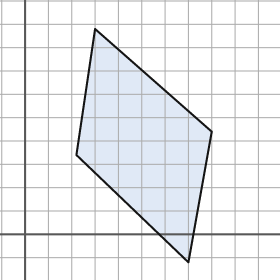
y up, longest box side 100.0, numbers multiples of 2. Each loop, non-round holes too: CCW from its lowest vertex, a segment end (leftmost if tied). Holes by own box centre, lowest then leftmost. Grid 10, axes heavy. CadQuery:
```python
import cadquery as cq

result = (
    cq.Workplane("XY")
    .moveTo(70.0, -12.0)
    .lineTo(80.0, 44.0)
    .lineTo(30.0, 88.0)
    .lineTo(22.0, 34.0)
    .close()
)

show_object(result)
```